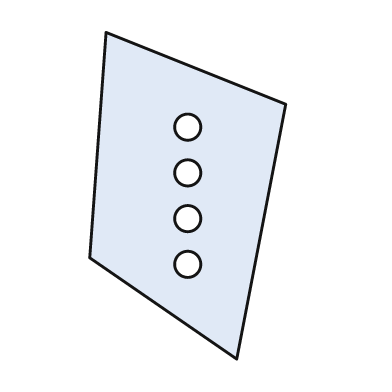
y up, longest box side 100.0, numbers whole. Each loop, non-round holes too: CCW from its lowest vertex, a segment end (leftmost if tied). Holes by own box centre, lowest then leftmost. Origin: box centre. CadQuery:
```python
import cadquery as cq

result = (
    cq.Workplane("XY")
    .moveTo(15.0, -50.0)
    .lineTo(30.0, 28.0)
    .lineTo(-25.0, 50.0)
    .lineTo(-30.0, -19.0)
    .close()
    .moveTo(0.0, -21.0)
    .circle(4.0)
    .moveTo(0.0, -7.0)
    .circle(4.0)
    .moveTo(0.0, 7.0)
    .circle(4.0)
    .moveTo(0.0, 21.0)
    .circle(4.0)
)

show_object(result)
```